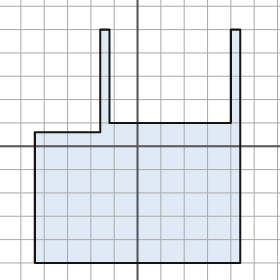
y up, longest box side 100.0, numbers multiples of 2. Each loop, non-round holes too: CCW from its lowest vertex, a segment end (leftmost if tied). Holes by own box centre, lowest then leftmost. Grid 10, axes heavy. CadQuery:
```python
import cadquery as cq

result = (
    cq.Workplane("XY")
    .moveTo(-44.0, -50.0)
    .lineTo(44.0, -50.0)
    .lineTo(44.0, 50.0)
    .lineTo(40.0, 50.0)
    .lineTo(40.0, 10.0)
    .lineTo(-12.0, 10.0)
    .lineTo(-12.0, 50.0)
    .lineTo(-16.0, 50.0)
    .lineTo(-16.0, 6.0)
    .lineTo(-44.0, 6.0)
    .close()
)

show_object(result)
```